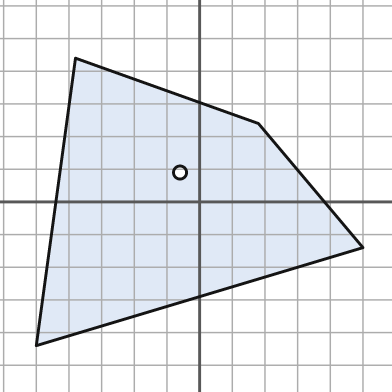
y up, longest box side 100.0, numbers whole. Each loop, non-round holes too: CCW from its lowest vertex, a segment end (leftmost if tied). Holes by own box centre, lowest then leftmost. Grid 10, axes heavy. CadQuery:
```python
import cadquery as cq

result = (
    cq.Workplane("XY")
    .moveTo(-50.0, -44.0)
    .lineTo(50.0, -14.0)
    .lineTo(18.0, 24.0)
    .lineTo(-38.0, 44.0)
    .close()
    .moveTo(-6.0, 9.0)
    .circle(2.0)
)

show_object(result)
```